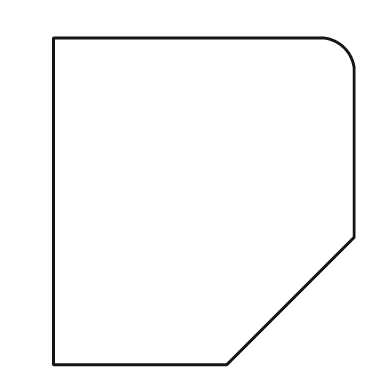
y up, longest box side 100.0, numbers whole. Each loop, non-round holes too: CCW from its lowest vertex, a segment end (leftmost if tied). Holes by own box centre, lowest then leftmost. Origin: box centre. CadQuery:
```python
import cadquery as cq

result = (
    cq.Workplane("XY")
    .moveTo(-46.0, -50.0)
    .lineTo(7.0, -50.0)
    .lineTo(46.0, -11.0)
    .lineTo(46.0, 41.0)
    .threePointArc((43.0, 47.0), (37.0, 50.0))
    .lineTo(-46.0, 50.0)
    .close()
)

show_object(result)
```